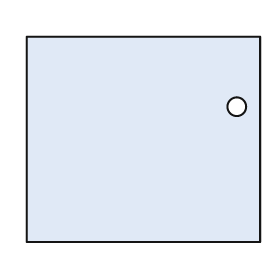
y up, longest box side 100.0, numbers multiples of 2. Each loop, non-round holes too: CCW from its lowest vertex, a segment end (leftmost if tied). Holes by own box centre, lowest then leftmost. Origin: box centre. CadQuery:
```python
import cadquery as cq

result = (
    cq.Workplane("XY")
    .moveTo(-50.0, -44.0)
    .lineTo(50.0, -44.0)
    .lineTo(50.0, 44.0)
    .lineTo(-50.0, 44.0)
    .close()
    .moveTo(40.0, 14.0)
    .circle(4.0)
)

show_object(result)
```